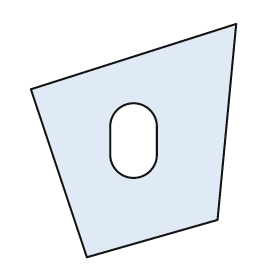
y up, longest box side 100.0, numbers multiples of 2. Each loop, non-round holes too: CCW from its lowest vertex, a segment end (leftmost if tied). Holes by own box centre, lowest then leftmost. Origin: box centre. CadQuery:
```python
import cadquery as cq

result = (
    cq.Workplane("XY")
    .moveTo(-20.0, -50.0)
    .lineTo(36.0, -34.0)
    .lineTo(44.0, 50.0)
    .lineTo(-44.0, 22.0)
    .close()
    .moveTo(-10.0, -6.0)
    .threePointArc((0.0, -16.0), (10.0, -6.0))
    .lineTo(10.0, 6.0)
    .threePointArc((0.0, 16.0), (-10.0, 6.0))
    .close()
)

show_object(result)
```